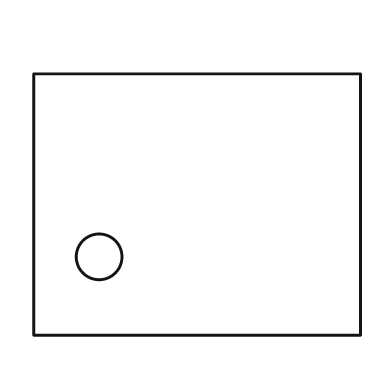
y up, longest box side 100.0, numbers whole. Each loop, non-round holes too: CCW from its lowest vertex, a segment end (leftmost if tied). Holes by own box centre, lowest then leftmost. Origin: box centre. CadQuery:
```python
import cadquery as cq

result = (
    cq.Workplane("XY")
    .moveTo(-50.0, -40.0)
    .lineTo(50.0, -40.0)
    .lineTo(50.0, 40.0)
    .lineTo(-50.0, 40.0)
    .close()
    .moveTo(-30.0, -16.0)
    .circle(7.0)
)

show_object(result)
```